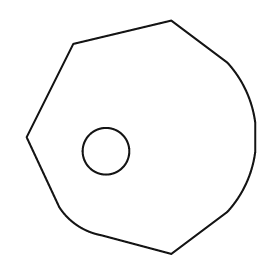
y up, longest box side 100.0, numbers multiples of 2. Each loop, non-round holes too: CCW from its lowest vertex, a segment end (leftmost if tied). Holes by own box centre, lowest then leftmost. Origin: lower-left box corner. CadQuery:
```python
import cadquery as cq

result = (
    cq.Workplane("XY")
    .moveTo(62.0, 0.0)
    .lineTo(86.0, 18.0)
    .threePointArc((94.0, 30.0), (98.0, 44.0))
    .lineTo(98.0, 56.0)
    .threePointArc((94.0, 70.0), (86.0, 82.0))
    .lineTo(62.0, 100.0)
    .lineTo(20.0, 90.0)
    .lineTo(0.0, 50.0)
    .lineTo(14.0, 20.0)
    .threePointArc((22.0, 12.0), (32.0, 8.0))
    .close()
    .moveTo(34.0, 44.0)
    .circle(10.0)
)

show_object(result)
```